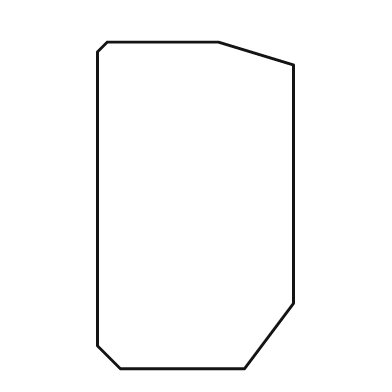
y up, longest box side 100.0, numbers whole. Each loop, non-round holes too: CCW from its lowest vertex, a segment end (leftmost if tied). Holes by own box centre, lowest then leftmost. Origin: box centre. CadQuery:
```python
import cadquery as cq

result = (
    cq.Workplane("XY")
    .moveTo(-23.0, -50.0)
    .lineTo(15.0, -50.0)
    .lineTo(30.0, -30.0)
    .lineTo(30.0, 43.0)
    .lineTo(7.0, 50.0)
    .lineTo(-27.0, 50.0)
    .lineTo(-30.0, 47.0)
    .lineTo(-30.0, -43.0)
    .close()
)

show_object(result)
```